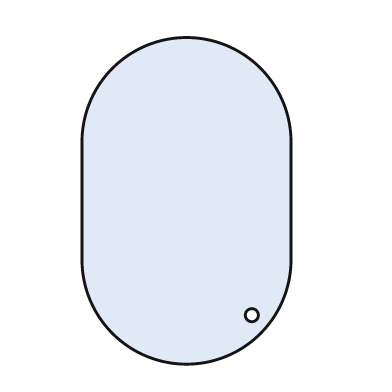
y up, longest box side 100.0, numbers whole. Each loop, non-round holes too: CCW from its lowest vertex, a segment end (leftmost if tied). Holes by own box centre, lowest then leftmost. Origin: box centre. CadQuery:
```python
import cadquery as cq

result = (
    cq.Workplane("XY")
    .moveTo(-32.0, -18.0)
    .threePointArc((0.0, -50.0), (32.0, -18.0))
    .lineTo(32.0, 18.0)
    .threePointArc((0.0, 50.0), (-32.0, 18.0))
    .close()
    .moveTo(20.0, -35.0)
    .circle(2.0)
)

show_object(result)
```